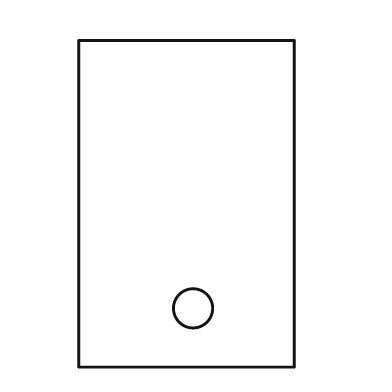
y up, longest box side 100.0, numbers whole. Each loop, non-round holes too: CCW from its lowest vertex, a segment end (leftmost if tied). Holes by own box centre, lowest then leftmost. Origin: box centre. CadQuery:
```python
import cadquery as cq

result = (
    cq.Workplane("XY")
    .moveTo(-33.0, -50.0)
    .lineTo(33.0, -50.0)
    .lineTo(33.0, 50.0)
    .lineTo(-33.0, 50.0)
    .close()
    .moveTo(2.0, -32.0)
    .circle(6.0)
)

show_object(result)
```